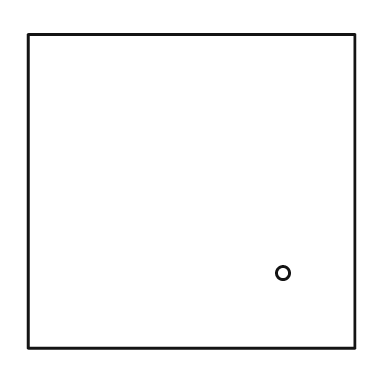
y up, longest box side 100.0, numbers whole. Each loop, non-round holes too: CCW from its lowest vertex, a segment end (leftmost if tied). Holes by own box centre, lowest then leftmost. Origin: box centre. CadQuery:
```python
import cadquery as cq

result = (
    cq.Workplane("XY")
    .moveTo(-50.0, -48.0)
    .lineTo(50.0, -48.0)
    .lineTo(50.0, 48.0)
    .lineTo(-50.0, 48.0)
    .close()
    .moveTo(28.0, -25.0)
    .circle(2.0)
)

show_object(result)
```